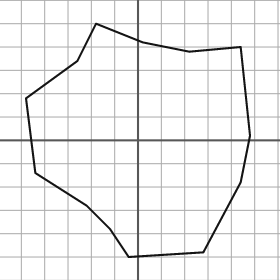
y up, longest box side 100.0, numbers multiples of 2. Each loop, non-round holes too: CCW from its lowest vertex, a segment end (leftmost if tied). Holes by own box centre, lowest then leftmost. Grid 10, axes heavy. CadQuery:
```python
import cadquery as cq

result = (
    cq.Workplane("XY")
    .moveTo(-4.0, -50.0)
    .lineTo(28.0, -48.0)
    .lineTo(44.0, -18.0)
    .lineTo(48.0, 2.0)
    .lineTo(44.0, 40.0)
    .lineTo(22.0, 38.0)
    .lineTo(2.0, 42.0)
    .lineTo(-18.0, 50.0)
    .lineTo(-26.0, 34.0)
    .lineTo(-48.0, 18.0)
    .lineTo(-44.0, -14.0)
    .lineTo(-22.0, -28.0)
    .lineTo(-12.0, -38.0)
    .close()
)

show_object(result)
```